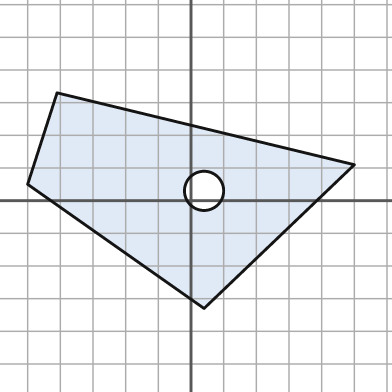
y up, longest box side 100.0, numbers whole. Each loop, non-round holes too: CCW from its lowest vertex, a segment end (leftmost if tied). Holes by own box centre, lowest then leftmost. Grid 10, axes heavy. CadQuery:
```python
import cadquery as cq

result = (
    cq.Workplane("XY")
    .moveTo(4.0, -33.0)
    .lineTo(50.0, 11.0)
    .lineTo(-41.0, 33.0)
    .lineTo(-50.0, 5.0)
    .close()
    .moveTo(4.0, 3.0)
    .circle(6.0)
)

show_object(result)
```